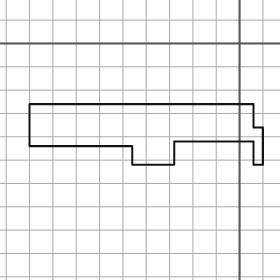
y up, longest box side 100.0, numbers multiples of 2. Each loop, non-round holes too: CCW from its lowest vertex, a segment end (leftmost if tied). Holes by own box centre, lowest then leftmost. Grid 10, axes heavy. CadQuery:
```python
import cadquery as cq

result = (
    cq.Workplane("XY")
    .moveTo(-46.0, -52.0)
    .lineTo(-28.0, -52.0)
    .lineTo(-28.0, -42.0)
    .lineTo(6.0, -42.0)
    .lineTo(6.0, -52.0)
    .lineTo(10.0, -52.0)
    .lineTo(10.0, -36.0)
    .lineTo(6.0, -36.0)
    .lineTo(6.0, -26.0)
    .lineTo(-90.0, -26.0)
    .lineTo(-90.0, -44.0)
    .lineTo(-46.0, -44.0)
    .close()
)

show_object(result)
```